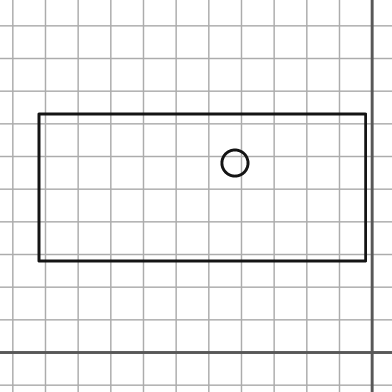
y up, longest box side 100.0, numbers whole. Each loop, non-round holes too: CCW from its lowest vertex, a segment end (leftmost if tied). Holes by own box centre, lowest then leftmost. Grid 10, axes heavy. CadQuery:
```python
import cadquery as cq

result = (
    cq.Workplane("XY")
    .moveTo(-102.0, 28.0)
    .lineTo(-2.0, 28.0)
    .lineTo(-2.0, 73.0)
    .lineTo(-102.0, 73.0)
    .close()
    .moveTo(-42.0, 58.0)
    .circle(4.0)
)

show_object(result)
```